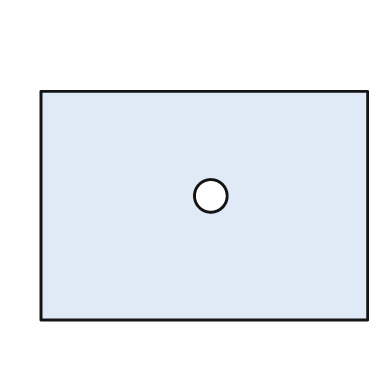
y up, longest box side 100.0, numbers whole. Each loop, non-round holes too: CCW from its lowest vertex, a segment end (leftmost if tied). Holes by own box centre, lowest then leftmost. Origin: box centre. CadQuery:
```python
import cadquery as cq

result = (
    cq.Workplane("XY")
    .moveTo(-50.0, -35.0)
    .lineTo(50.0, -35.0)
    .lineTo(50.0, 35.0)
    .lineTo(-50.0, 35.0)
    .close()
    .moveTo(2.0, 3.0)
    .circle(5.0)
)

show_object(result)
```